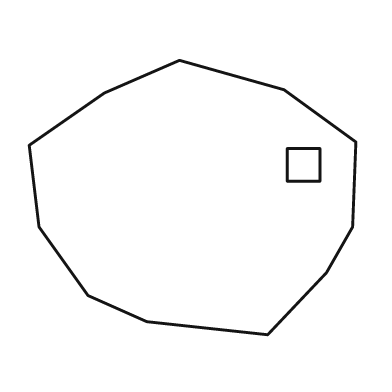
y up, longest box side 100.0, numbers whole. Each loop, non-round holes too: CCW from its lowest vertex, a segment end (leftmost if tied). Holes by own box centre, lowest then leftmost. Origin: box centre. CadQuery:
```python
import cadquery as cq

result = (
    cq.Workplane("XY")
    .moveTo(23.0, -42.0)
    .lineTo(41.0, -23.0)
    .lineTo(49.0, -9.0)
    .lineTo(50.0, 17.0)
    .lineTo(28.0, 33.0)
    .lineTo(-4.0, 42.0)
    .lineTo(-27.0, 32.0)
    .lineTo(-50.0, 16.0)
    .lineTo(-47.0, -9.0)
    .lineTo(-32.0, -30.0)
    .lineTo(-14.0, -38.0)
    .close()
    .moveTo(29.0, 5.0)
    .lineTo(39.0, 5.0)
    .lineTo(39.0, 15.0)
    .lineTo(29.0, 15.0)
    .close()
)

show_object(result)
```